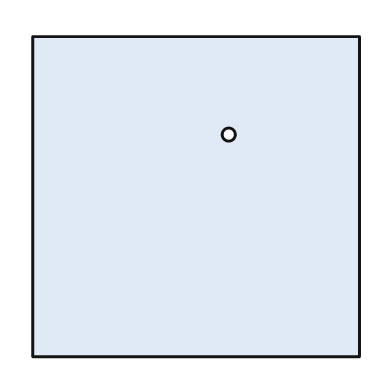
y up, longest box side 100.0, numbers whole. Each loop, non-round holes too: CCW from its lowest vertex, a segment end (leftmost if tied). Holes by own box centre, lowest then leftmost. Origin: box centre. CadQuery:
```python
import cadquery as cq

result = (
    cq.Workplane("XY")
    .moveTo(-50.0, -49.0)
    .lineTo(50.0, -49.0)
    .lineTo(50.0, 49.0)
    .lineTo(-50.0, 49.0)
    .close()
    .moveTo(10.0, 19.0)
    .circle(2.0)
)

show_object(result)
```